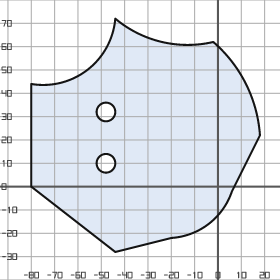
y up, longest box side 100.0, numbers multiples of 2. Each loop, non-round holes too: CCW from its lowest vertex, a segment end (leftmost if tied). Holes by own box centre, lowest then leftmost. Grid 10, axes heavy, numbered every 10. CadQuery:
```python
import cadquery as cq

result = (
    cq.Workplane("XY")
    .moveTo(-44.0, -28.0)
    .lineTo(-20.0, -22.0)
    .threePointArc((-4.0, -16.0), (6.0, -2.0))
    .lineTo(18.0, 22.0)
    .threePointArc((12.0, 44.0), (-2.0, 62.0))
    .threePointArc((-24.0, 62.0), (-44.0, 72.0))
    .threePointArc((-56.0, 50.0), (-80.0, 44.0))
    .lineTo(-80.0, 0.0)
    .close()
    .moveTo(-48.0, 10.0)
    .circle(4.0)
    .moveTo(-48.0, 32.0)
    .circle(4.0)
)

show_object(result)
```